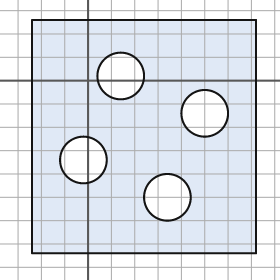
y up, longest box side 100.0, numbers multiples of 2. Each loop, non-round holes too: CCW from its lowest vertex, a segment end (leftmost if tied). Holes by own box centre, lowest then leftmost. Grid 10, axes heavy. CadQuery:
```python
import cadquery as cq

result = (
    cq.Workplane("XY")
    .moveTo(-24.0, -74.0)
    .lineTo(72.0, -74.0)
    .lineTo(72.0, 26.0)
    .lineTo(-24.0, 26.0)
    .close()
    .moveTo(34.0, -50.0)
    .circle(10.0)
    .moveTo(-2.0, -34.0)
    .circle(10.0)
    .moveTo(50.0, -14.0)
    .circle(10.0)
    .moveTo(14.0, 2.0)
    .circle(10.0)
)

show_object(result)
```